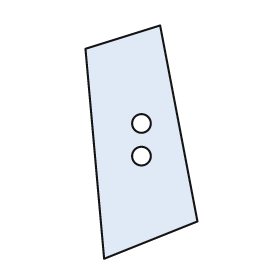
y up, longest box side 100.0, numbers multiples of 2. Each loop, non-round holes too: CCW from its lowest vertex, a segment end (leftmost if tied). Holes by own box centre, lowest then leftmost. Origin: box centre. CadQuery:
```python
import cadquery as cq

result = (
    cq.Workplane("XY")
    .moveTo(-16.0, -50.0)
    .lineTo(24.0, -34.0)
    .lineTo(8.0, 50.0)
    .lineTo(-24.0, 40.0)
    .close()
    .moveTo(0.0, -6.0)
    .circle(4.0)
    .moveTo(0.0, 8.0)
    .circle(4.0)
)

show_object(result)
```